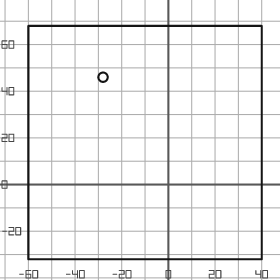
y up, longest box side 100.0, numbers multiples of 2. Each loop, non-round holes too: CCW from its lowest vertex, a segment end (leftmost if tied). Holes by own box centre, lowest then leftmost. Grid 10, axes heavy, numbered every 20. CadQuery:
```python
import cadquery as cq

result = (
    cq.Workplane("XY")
    .moveTo(-60.0, -32.0)
    .lineTo(40.0, -32.0)
    .lineTo(40.0, 68.0)
    .lineTo(-60.0, 68.0)
    .close()
    .moveTo(-28.0, 46.0)
    .circle(2.0)
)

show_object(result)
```